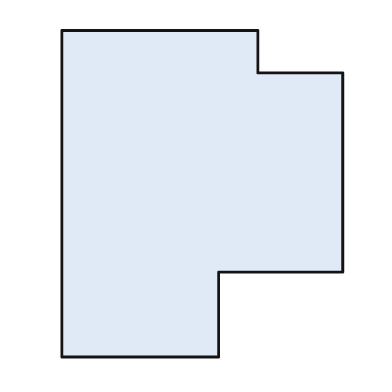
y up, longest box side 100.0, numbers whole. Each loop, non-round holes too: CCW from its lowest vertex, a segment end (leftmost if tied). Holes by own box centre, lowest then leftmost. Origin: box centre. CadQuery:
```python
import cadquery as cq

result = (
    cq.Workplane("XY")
    .moveTo(-43.0, -50.0)
    .lineTo(5.0, -50.0)
    .lineTo(5.0, -24.0)
    .lineTo(43.0, -24.0)
    .lineTo(43.0, 37.0)
    .lineTo(17.0, 37.0)
    .lineTo(17.0, 50.0)
    .lineTo(-43.0, 50.0)
    .close()
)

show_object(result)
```